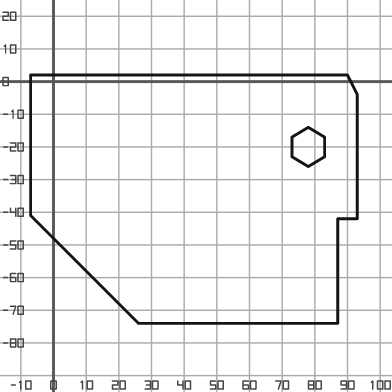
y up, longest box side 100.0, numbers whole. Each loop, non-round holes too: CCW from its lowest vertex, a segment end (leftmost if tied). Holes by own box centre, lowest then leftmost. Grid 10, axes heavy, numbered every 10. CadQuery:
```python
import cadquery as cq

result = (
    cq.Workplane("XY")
    .moveTo(26.0, -74.0)
    .lineTo(87.0, -74.0)
    .lineTo(87.0, -42.0)
    .lineTo(93.0, -42.0)
    .lineTo(93.0, -4.0)
    .lineTo(90.0, 2.0)
    .lineTo(-7.0, 2.0)
    .lineTo(-7.0, -41.0)
    .close()
    .moveTo(78.0, -26.0)
    .lineTo(83.0, -23.0)
    .lineTo(83.0, -17.0)
    .lineTo(78.0, -14.0)
    .lineTo(73.0, -17.0)
    .lineTo(73.0, -23.0)
    .close()
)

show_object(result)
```